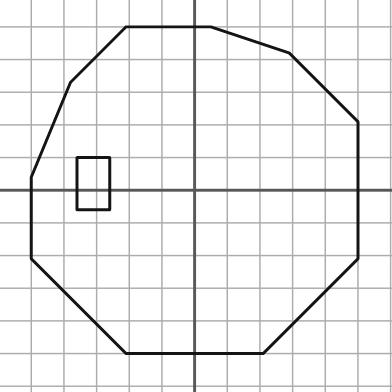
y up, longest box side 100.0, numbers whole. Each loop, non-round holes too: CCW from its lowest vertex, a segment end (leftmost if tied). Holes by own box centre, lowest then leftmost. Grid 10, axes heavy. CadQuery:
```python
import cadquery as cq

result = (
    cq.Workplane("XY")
    .moveTo(-21.0, -50.0)
    .lineTo(21.0, -50.0)
    .lineTo(50.0, -21.0)
    .lineTo(50.0, 21.0)
    .lineTo(29.0, 42.0)
    .lineTo(5.0, 50.0)
    .lineTo(-21.0, 50.0)
    .lineTo(-38.0, 33.0)
    .lineTo(-50.0, 4.0)
    .lineTo(-50.0, -21.0)
    .close()
    .moveTo(-36.0, -6.0)
    .lineTo(-26.0, -6.0)
    .lineTo(-26.0, 10.0)
    .lineTo(-36.0, 10.0)
    .close()
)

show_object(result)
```